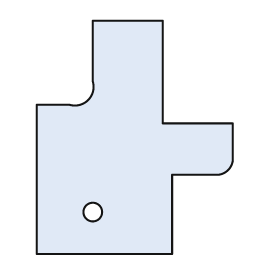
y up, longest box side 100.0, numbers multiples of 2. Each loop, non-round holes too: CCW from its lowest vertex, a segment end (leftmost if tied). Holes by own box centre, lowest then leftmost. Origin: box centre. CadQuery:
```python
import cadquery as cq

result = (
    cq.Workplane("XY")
    .moveTo(-42.0, -50.0)
    .lineTo(16.0, -50.0)
    .lineTo(16.0, -16.0)
    .lineTo(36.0, -16.0)
    .threePointArc((40.0, -14.0), (42.0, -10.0))
    .lineTo(42.0, 6.0)
    .lineTo(12.0, 6.0)
    .lineTo(12.0, 50.0)
    .lineTo(-18.0, 50.0)
    .lineTo(-18.0, 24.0)
    .threePointArc((-20.0, 16.0), (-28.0, 14.0))
    .lineTo(-42.0, 14.0)
    .close()
    .moveTo(-18.0, -32.0)
    .circle(4.0)
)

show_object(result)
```